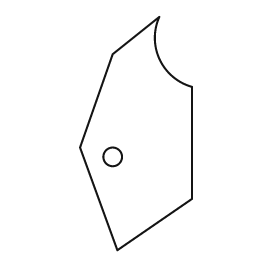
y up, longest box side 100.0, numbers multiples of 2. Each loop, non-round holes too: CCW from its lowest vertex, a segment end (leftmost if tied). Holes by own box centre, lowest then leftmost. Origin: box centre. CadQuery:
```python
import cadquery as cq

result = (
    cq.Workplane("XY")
    .moveTo(-8.0, -50.0)
    .lineTo(24.0, -28.0)
    .lineTo(24.0, 20.0)
    .threePointArc((10.0, 32.0), (10.0, 50.0))
    .lineTo(-10.0, 34.0)
    .lineTo(-24.0, -6.0)
    .close()
    .moveTo(-10.0, -10.0)
    .circle(4.0)
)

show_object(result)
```